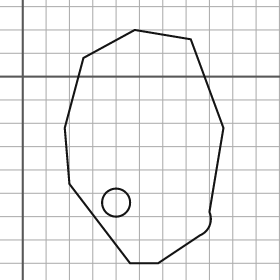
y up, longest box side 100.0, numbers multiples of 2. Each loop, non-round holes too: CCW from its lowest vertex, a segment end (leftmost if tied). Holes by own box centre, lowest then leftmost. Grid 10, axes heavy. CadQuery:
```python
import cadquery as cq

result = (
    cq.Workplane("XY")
    .moveTo(46.0, -80.0)
    .lineTo(58.0, -80.0)
    .lineTo(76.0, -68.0)
    .threePointArc((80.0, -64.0), (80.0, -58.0))
    .lineTo(86.0, -22.0)
    .lineTo(72.0, 16.0)
    .lineTo(48.0, 20.0)
    .lineTo(26.0, 8.0)
    .lineTo(18.0, -22.0)
    .lineTo(20.0, -46.0)
    .close()
    .moveTo(40.0, -54.0)
    .circle(6.0)
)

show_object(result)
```